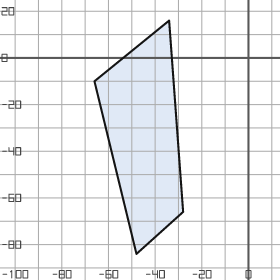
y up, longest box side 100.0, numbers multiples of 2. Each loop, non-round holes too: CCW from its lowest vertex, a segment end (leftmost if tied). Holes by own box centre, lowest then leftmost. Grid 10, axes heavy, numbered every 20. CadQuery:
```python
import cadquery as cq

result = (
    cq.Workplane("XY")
    .moveTo(-48.0, -84.0)
    .lineTo(-28.0, -66.0)
    .lineTo(-34.0, 16.0)
    .lineTo(-66.0, -10.0)
    .close()
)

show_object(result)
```